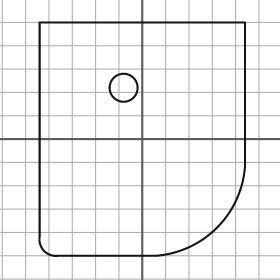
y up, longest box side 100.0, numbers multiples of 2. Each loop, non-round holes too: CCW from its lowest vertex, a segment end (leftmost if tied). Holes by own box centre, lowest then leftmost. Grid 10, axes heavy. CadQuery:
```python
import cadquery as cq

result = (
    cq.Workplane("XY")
    .moveTo(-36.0, -50.0)
    .lineTo(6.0, -50.0)
    .threePointArc((32.0, -38.0), (44.0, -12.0))
    .lineTo(44.0, 50.0)
    .lineTo(-44.0, 50.0)
    .lineTo(-44.0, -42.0)
    .threePointArc((-42.0, -48.0), (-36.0, -50.0))
    .close()
    .moveTo(-8.0, 22.0)
    .circle(6.0)
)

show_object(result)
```